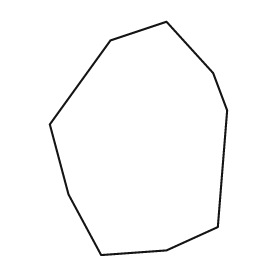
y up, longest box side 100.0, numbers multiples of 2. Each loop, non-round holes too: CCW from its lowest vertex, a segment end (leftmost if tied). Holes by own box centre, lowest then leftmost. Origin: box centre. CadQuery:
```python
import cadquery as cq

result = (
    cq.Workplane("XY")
    .moveTo(-16.0, -50.0)
    .lineTo(12.0, -48.0)
    .lineTo(34.0, -38.0)
    .lineTo(38.0, 12.0)
    .lineTo(32.0, 28.0)
    .lineTo(12.0, 50.0)
    .lineTo(-12.0, 42.0)
    .lineTo(-38.0, 6.0)
    .lineTo(-30.0, -24.0)
    .close()
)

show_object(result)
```